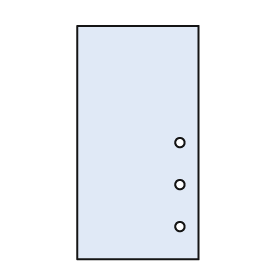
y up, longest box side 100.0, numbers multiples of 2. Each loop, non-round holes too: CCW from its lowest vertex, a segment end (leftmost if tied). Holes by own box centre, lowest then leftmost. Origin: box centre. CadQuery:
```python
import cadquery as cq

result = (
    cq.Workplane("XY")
    .moveTo(-26.0, -50.0)
    .lineTo(26.0, -50.0)
    .lineTo(26.0, 50.0)
    .lineTo(-26.0, 50.0)
    .close()
    .moveTo(18.0, -36.0)
    .circle(2.0)
    .moveTo(18.0, -18.0)
    .circle(2.0)
    .moveTo(18.0, 0.0)
    .circle(2.0)
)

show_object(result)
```